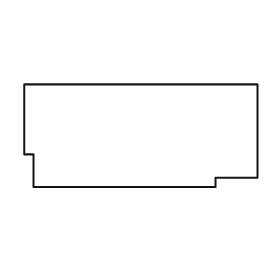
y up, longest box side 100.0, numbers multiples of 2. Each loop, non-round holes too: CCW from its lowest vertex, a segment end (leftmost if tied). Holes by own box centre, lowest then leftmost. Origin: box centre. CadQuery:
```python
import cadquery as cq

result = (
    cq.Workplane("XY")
    .moveTo(-46.0, -22.0)
    .lineTo(32.0, -22.0)
    .lineTo(32.0, -18.0)
    .lineTo(50.0, -18.0)
    .lineTo(50.0, 22.0)
    .lineTo(-50.0, 22.0)
    .lineTo(-50.0, -8.0)
    .lineTo(-46.0, -8.0)
    .close()
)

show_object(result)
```